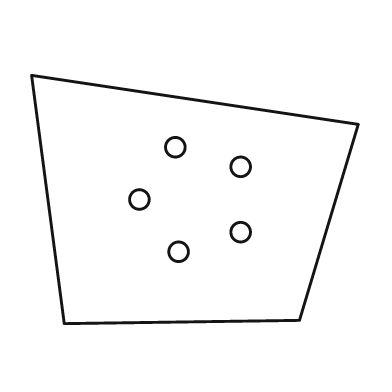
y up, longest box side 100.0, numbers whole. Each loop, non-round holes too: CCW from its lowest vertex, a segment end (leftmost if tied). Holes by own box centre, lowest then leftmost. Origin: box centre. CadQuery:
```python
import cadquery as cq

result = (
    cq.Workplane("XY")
    .moveTo(-40.0, -38.0)
    .lineTo(32.0, -37.0)
    .lineTo(50.0, 23.0)
    .lineTo(-50.0, 38.0)
    .close()
    .moveTo(-5.0, -16.0)
    .circle(3.0)
    .moveTo(14.0, -10.0)
    .circle(3.0)
    .moveTo(-17.0, 0.0)
    .circle(3.0)
    .moveTo(14.0, 10.0)
    .circle(3.0)
    .moveTo(-6.0, 16.0)
    .circle(3.0)
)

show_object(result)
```